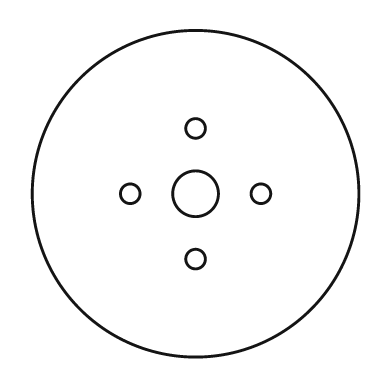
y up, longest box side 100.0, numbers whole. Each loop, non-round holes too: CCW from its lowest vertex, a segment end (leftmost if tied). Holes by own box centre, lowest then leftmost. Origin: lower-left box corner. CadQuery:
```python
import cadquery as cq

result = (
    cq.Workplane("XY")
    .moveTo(50.0, 50.0)
    .circle(50.0)
    .moveTo(50.0, 30.0)
    .circle(3.0)
    .moveTo(30.0, 50.0)
    .circle(3.0)
    .moveTo(50.0, 50.0)
    .circle(7.0)
    .moveTo(70.0, 50.0)
    .circle(3.0)
    .moveTo(50.0, 70.0)
    .circle(3.0)
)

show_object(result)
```